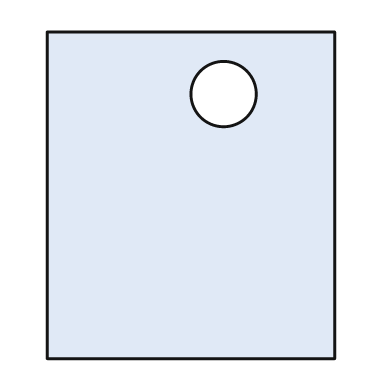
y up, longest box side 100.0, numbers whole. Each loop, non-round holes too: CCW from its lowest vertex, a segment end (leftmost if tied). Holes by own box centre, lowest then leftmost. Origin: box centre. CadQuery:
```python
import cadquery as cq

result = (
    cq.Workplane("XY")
    .moveTo(-44.0, -50.0)
    .lineTo(44.0, -50.0)
    .lineTo(44.0, 50.0)
    .lineTo(-44.0, 50.0)
    .close()
    .moveTo(10.0, 31.0)
    .circle(10.0)
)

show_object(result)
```